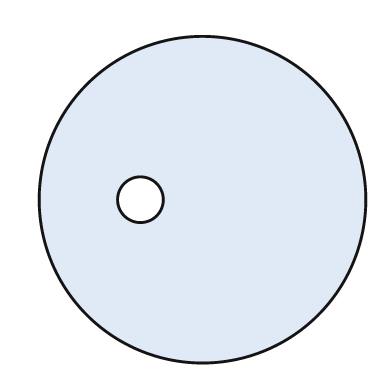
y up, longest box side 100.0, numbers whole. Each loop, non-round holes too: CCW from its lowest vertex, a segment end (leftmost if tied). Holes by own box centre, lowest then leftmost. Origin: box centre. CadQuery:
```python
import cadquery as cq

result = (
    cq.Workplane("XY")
    .moveTo(0.0, 0.0)
    .circle(50.0)
    .moveTo(-19.0, 0.0)
    .circle(7.0)
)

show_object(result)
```